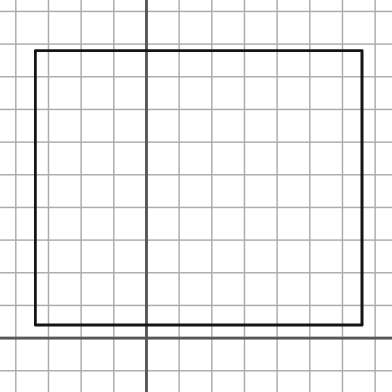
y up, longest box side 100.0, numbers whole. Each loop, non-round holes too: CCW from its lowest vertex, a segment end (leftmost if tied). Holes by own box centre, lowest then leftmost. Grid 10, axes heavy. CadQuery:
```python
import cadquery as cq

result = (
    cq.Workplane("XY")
    .moveTo(-34.0, 4.0)
    .lineTo(66.0, 4.0)
    .lineTo(66.0, 88.0)
    .lineTo(-34.0, 88.0)
    .close()
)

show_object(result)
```